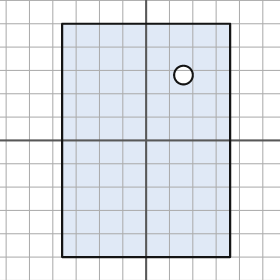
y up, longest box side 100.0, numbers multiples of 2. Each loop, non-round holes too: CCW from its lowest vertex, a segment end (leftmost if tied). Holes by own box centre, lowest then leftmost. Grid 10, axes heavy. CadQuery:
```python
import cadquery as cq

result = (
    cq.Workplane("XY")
    .moveTo(-36.0, -50.0)
    .lineTo(36.0, -50.0)
    .lineTo(36.0, 50.0)
    .lineTo(-36.0, 50.0)
    .close()
    .moveTo(16.0, 28.0)
    .circle(4.0)
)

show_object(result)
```